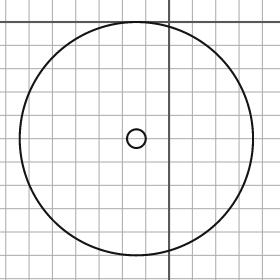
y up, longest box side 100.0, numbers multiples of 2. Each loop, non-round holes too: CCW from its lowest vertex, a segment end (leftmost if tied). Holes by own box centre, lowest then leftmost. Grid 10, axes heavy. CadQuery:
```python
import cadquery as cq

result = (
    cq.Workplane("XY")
    .moveTo(-14.0, -50.0)
    .circle(50.0)
    .moveTo(-14.0, -50.0)
    .circle(4.0)
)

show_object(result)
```